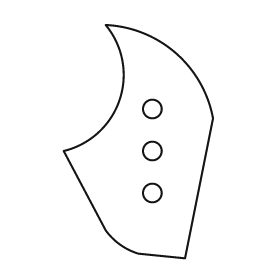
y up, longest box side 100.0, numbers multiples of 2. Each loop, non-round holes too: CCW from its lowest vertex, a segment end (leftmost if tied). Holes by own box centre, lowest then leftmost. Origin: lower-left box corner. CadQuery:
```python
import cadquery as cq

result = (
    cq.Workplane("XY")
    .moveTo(52.0, 0.0)
    .lineTo(64.0, 60.0)
    .threePointArc((48.0, 88.0), (18.0, 100.0))
    .threePointArc((24.0, 68.0), (0.0, 46.0))
    .lineTo(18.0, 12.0)
    .threePointArc((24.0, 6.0), (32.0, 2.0))
    .close()
    .moveTo(38.0, 28.0)
    .circle(4.0)
    .moveTo(38.0, 46.0)
    .circle(4.0)
    .moveTo(38.0, 64.0)
    .circle(4.0)
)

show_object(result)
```